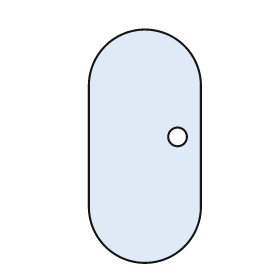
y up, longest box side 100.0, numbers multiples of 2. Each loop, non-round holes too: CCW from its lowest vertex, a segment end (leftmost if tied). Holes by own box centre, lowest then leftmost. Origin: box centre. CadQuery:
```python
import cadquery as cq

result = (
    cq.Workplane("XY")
    .moveTo(-24.0, -26.0)
    .threePointArc((0.0, -50.0), (24.0, -26.0))
    .lineTo(24.0, 26.0)
    .threePointArc((0.0, 50.0), (-24.0, 26.0))
    .close()
    .moveTo(14.0, 4.0)
    .circle(4.0)
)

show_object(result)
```